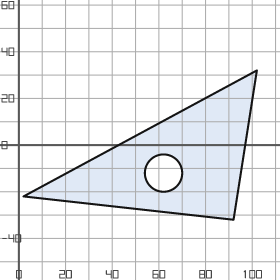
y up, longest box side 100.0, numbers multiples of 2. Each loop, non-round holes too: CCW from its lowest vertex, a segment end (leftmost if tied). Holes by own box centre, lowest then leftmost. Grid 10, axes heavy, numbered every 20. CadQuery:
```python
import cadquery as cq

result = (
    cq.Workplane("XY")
    .moveTo(92.0, -32.0)
    .lineTo(102.0, 32.0)
    .lineTo(2.0, -22.0)
    .close()
    .moveTo(62.0, -12.0)
    .circle(8.0)
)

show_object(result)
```